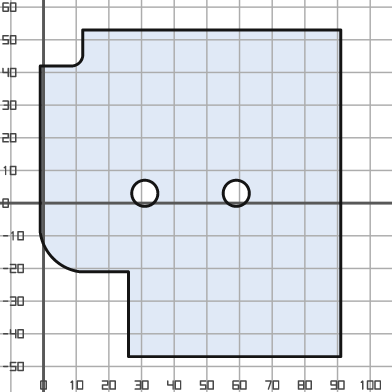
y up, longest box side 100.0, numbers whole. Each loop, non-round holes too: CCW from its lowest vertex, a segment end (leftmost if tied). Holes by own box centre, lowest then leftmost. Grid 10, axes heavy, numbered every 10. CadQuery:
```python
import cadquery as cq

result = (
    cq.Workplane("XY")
    .moveTo(26.0, -47.0)
    .lineTo(91.0, -47.0)
    .lineTo(91.0, 53.0)
    .lineTo(12.0, 53.0)
    .lineTo(12.0, 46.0)
    .threePointArc((11.0, 43.0), (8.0, 42.0))
    .lineTo(-1.0, 42.0)
    .lineTo(-1.0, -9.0)
    .threePointArc((3.0, -17.0), (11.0, -21.0))
    .lineTo(26.0, -21.0)
    .close()
    .moveTo(31.0, 3.0)
    .circle(4.0)
    .moveTo(59.0, 3.0)
    .circle(4.0)
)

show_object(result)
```